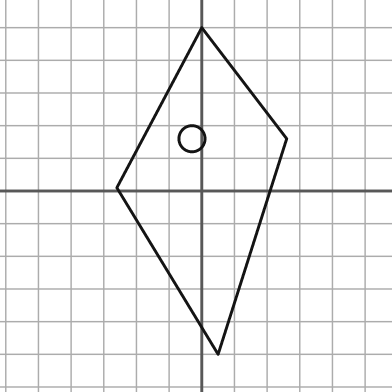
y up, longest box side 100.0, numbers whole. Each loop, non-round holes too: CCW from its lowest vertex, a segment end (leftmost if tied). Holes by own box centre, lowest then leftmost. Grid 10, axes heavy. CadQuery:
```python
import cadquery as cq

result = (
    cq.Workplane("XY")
    .moveTo(5.0, -50.0)
    .lineTo(26.0, 16.0)
    .lineTo(0.0, 50.0)
    .lineTo(-26.0, 1.0)
    .close()
    .moveTo(-3.0, 16.0)
    .circle(4.0)
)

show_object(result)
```